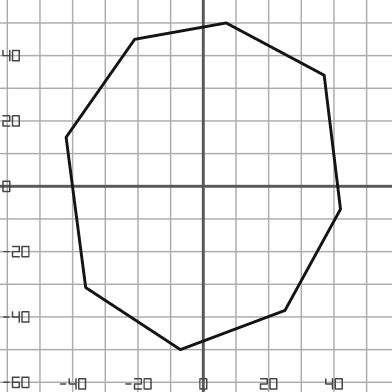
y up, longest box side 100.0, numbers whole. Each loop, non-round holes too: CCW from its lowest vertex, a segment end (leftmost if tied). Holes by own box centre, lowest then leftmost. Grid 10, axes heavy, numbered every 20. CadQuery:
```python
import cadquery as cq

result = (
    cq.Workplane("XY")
    .moveTo(-7.0, -50.0)
    .lineTo(25.0, -38.0)
    .lineTo(42.0, -7.0)
    .lineTo(37.0, 34.0)
    .lineTo(7.0, 50.0)
    .lineTo(-21.0, 45.0)
    .lineTo(-42.0, 15.0)
    .lineTo(-36.0, -31.0)
    .close()
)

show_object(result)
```